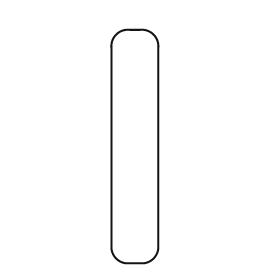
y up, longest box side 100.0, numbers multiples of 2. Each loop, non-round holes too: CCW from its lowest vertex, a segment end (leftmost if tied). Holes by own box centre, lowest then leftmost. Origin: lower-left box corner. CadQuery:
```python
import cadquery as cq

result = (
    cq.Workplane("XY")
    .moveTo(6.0, 0.0)
    .lineTo(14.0, 0.0)
    .threePointArc((18.0, 2.0), (20.0, 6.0))
    .lineTo(20.0, 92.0)
    .threePointArc((18.0, 98.0), (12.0, 100.0))
    .lineTo(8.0, 100.0)
    .threePointArc((2.0, 98.0), (0.0, 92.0))
    .lineTo(0.0, 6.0)
    .threePointArc((2.0, 2.0), (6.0, 0.0))
    .close()
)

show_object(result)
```